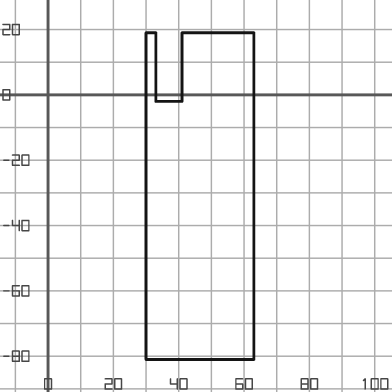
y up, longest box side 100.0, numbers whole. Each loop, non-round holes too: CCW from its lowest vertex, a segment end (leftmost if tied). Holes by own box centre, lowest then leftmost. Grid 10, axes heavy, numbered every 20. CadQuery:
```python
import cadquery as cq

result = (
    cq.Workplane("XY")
    .moveTo(30.0, -81.0)
    .lineTo(63.0, -81.0)
    .lineTo(63.0, 19.0)
    .lineTo(41.0, 19.0)
    .lineTo(41.0, -2.0)
    .lineTo(33.0, -2.0)
    .lineTo(33.0, 19.0)
    .lineTo(30.0, 19.0)
    .close()
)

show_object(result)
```